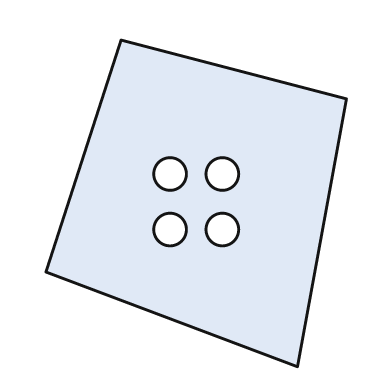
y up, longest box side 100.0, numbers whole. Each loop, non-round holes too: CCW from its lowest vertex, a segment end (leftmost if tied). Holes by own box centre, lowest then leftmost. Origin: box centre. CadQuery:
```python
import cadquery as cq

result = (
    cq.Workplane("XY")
    .moveTo(31.0, -50.0)
    .lineTo(46.0, 32.0)
    .lineTo(-23.0, 50.0)
    .lineTo(-46.0, -21.0)
    .close()
    .moveTo(-8.0, -8.0)
    .circle(5.0)
    .moveTo(8.0, -8.0)
    .circle(5.0)
    .moveTo(-8.0, 9.0)
    .circle(5.0)
    .moveTo(8.0, 9.0)
    .circle(5.0)
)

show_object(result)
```